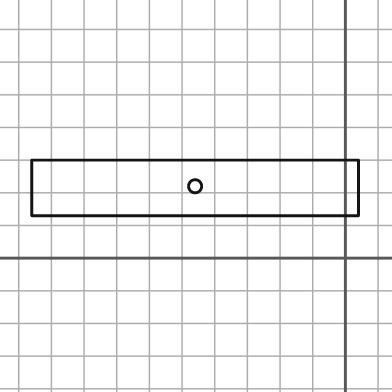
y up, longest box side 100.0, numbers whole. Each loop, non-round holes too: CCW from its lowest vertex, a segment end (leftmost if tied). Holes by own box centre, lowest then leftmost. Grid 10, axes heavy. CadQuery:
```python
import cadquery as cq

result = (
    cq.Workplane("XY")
    .moveTo(-96.0, 13.0)
    .lineTo(4.0, 13.0)
    .lineTo(4.0, 30.0)
    .lineTo(-96.0, 30.0)
    .close()
    .moveTo(-46.0, 22.0)
    .circle(2.0)
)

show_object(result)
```